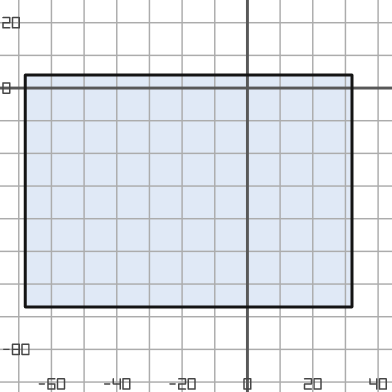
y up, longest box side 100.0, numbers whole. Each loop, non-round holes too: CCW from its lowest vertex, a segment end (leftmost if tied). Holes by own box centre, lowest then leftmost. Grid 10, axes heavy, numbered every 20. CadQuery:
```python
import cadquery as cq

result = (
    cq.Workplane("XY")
    .moveTo(-68.0, -67.0)
    .lineTo(32.0, -67.0)
    .lineTo(32.0, 4.0)
    .lineTo(-68.0, 4.0)
    .close()
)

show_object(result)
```